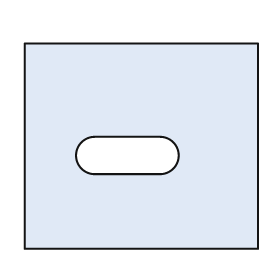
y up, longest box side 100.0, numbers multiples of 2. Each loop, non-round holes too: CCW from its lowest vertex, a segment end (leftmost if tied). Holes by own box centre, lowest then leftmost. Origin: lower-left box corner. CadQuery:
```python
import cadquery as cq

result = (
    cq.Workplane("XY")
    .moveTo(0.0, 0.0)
    .lineTo(100.0, 0.0)
    .lineTo(100.0, 88.0)
    .lineTo(0.0, 88.0)
    .close()
    .moveTo(30.0, 32.0)
    .lineTo(58.0, 32.0)
    .threePointArc((66.0, 40.0), (58.0, 48.0))
    .lineTo(30.0, 48.0)
    .threePointArc((22.0, 40.0), (30.0, 32.0))
    .close()
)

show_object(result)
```